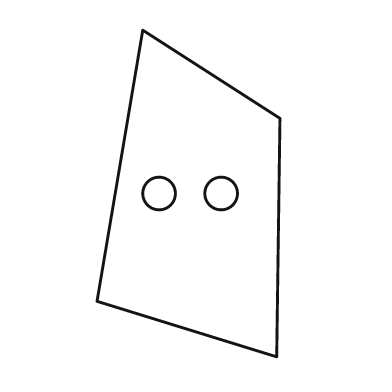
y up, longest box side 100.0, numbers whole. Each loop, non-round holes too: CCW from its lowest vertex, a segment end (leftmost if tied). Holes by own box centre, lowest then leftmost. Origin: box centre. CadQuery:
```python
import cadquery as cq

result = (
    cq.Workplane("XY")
    .moveTo(27.0, -50.0)
    .lineTo(28.0, 23.0)
    .lineTo(-14.0, 50.0)
    .lineTo(-28.0, -33.0)
    .close()
    .moveTo(-9.0, 0.0)
    .circle(5.0)
    .moveTo(10.0, 0.0)
    .circle(5.0)
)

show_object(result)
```